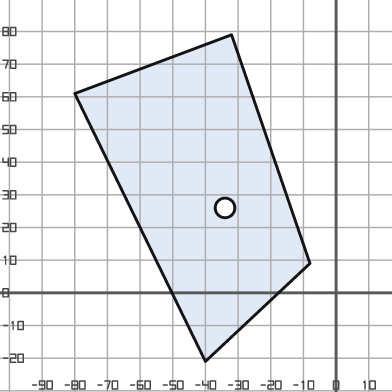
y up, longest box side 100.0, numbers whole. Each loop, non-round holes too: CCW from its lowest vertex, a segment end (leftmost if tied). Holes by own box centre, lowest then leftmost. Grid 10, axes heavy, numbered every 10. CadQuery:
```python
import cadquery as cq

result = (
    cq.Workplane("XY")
    .moveTo(-40.0, -21.0)
    .lineTo(-8.0, 9.0)
    .lineTo(-32.0, 79.0)
    .lineTo(-80.0, 61.0)
    .close()
    .moveTo(-34.0, 26.0)
    .circle(3.0)
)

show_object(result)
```